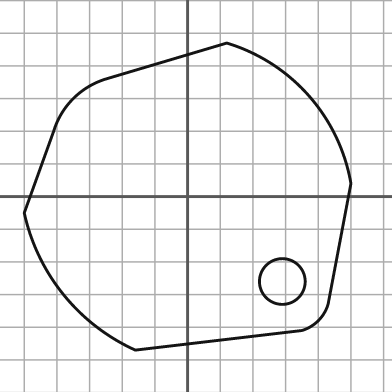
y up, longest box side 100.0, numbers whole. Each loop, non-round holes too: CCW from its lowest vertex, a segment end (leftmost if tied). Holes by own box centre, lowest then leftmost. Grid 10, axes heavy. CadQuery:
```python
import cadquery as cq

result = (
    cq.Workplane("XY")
    .moveTo(-16.0, -47.0)
    .lineTo(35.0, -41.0)
    .threePointArc((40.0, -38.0), (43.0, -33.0))
    .lineTo(50.0, 4.0)
    .threePointArc((37.0, 31.0), (12.0, 47.0))
    .lineTo(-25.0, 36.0)
    .threePointArc((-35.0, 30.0), (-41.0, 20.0))
    .lineTo(-50.0, -5.0)
    .threePointArc((-38.0, -30.0), (-16.0, -47.0))
    .close()
    .moveTo(29.0, -26.0)
    .circle(7.0)
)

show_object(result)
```